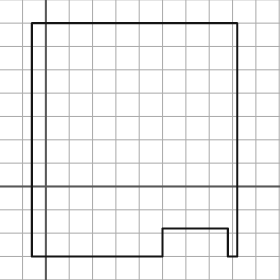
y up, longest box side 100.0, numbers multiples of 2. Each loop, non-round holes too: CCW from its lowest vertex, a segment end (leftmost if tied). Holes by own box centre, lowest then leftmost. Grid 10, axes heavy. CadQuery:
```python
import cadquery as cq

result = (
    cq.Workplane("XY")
    .moveTo(-6.0, -30.0)
    .lineTo(50.0, -30.0)
    .lineTo(50.0, -18.0)
    .lineTo(78.0, -18.0)
    .lineTo(78.0, -30.0)
    .lineTo(82.0, -30.0)
    .lineTo(82.0, 70.0)
    .lineTo(-6.0, 70.0)
    .close()
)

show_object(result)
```